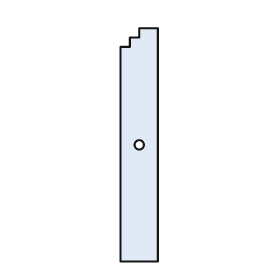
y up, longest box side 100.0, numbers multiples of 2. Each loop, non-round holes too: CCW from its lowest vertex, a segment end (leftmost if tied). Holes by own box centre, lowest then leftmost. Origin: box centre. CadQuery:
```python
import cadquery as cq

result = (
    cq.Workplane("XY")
    .moveTo(-8.0, -50.0)
    .lineTo(8.0, -50.0)
    .lineTo(8.0, 50.0)
    .lineTo(0.0, 50.0)
    .lineTo(0.0, 46.0)
    .lineTo(-4.0, 46.0)
    .lineTo(-4.0, 42.0)
    .lineTo(-8.0, 42.0)
    .close()
    .moveTo(0.0, 0.0)
    .circle(2.0)
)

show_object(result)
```